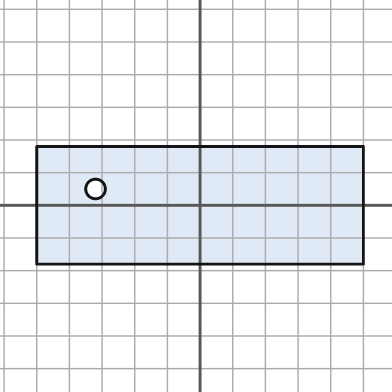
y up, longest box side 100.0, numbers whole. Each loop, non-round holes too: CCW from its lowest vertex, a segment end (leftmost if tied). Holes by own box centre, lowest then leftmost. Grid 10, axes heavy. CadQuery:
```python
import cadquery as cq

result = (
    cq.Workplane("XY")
    .moveTo(-50.0, -18.0)
    .lineTo(50.0, -18.0)
    .lineTo(50.0, 18.0)
    .lineTo(-50.0, 18.0)
    .close()
    .moveTo(-32.0, 5.0)
    .circle(3.0)
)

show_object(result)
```